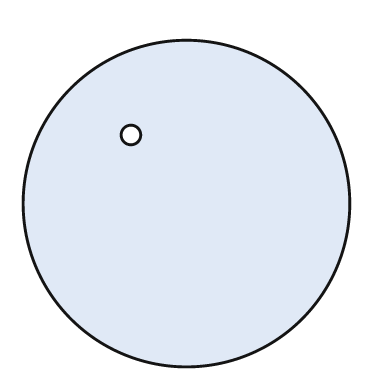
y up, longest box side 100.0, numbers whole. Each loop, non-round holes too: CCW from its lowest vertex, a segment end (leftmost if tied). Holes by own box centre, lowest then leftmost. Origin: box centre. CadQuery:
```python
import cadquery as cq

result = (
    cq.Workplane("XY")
    .moveTo(0.0, 0.0)
    .circle(50.0)
    .moveTo(-17.0, 21.0)
    .circle(3.0)
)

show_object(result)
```